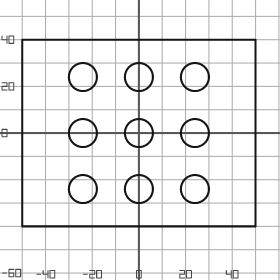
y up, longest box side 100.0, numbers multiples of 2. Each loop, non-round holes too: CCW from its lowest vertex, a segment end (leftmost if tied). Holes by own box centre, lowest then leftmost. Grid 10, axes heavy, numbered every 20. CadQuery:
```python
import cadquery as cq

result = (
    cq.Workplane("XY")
    .moveTo(-50.0, -40.0)
    .lineTo(50.0, -40.0)
    .lineTo(50.0, 40.0)
    .lineTo(-50.0, 40.0)
    .close()
    .moveTo(-24.0, -24.0)
    .circle(6.0)
    .moveTo(0.0, -24.0)
    .circle(6.0)
    .moveTo(24.0, -24.0)
    .circle(6.0)
    .moveTo(-24.0, 0.0)
    .circle(6.0)
    .moveTo(0.0, 0.0)
    .circle(6.0)
    .moveTo(24.0, 0.0)
    .circle(6.0)
    .moveTo(-24.0, 24.0)
    .circle(6.0)
    .moveTo(0.0, 24.0)
    .circle(6.0)
    .moveTo(24.0, 24.0)
    .circle(6.0)
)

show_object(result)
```